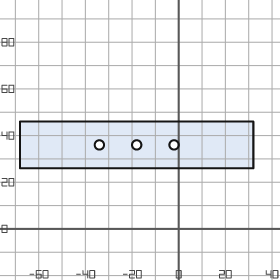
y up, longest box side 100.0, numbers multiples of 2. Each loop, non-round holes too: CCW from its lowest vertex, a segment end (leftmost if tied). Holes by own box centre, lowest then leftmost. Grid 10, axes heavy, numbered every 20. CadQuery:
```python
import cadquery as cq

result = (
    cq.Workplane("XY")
    .moveTo(-68.0, 26.0)
    .lineTo(32.0, 26.0)
    .lineTo(32.0, 46.0)
    .lineTo(-68.0, 46.0)
    .close()
    .moveTo(-34.0, 36.0)
    .circle(2.0)
    .moveTo(-18.0, 36.0)
    .circle(2.0)
    .moveTo(-2.0, 36.0)
    .circle(2.0)
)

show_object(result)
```